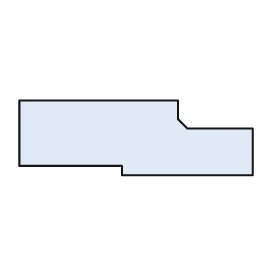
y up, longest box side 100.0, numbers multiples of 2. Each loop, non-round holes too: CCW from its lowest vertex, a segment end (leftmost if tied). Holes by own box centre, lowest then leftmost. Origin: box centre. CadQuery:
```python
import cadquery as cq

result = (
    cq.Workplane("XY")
    .moveTo(-6.0, -16.0)
    .lineTo(50.0, -16.0)
    .lineTo(50.0, 4.0)
    .lineTo(22.0, 4.0)
    .lineTo(18.0, 8.0)
    .lineTo(18.0, 16.0)
    .lineTo(-50.0, 16.0)
    .lineTo(-50.0, -12.0)
    .lineTo(-6.0, -12.0)
    .close()
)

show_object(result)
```